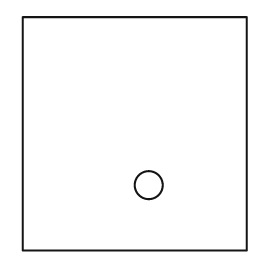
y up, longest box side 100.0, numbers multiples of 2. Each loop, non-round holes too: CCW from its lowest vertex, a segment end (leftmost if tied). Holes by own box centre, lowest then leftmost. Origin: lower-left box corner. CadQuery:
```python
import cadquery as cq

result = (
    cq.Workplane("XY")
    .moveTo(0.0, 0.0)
    .lineTo(96.0, 0.0)
    .lineTo(96.0, 100.0)
    .lineTo(0.0, 100.0)
    .close()
    .moveTo(54.0, 28.0)
    .circle(6.0)
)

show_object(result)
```